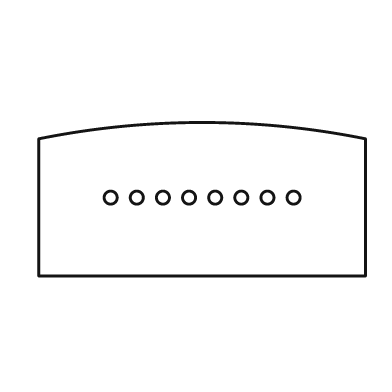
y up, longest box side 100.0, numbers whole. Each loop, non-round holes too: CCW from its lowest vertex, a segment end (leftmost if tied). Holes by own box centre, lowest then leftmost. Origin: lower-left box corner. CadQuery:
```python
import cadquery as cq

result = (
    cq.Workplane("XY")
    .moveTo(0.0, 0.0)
    .lineTo(100.0, 0.0)
    .lineTo(100.0, 42.0)
    .threePointArc((50.0, 47.0), (0.0, 42.0))
    .close()
    .moveTo(22.0, 24.0)
    .circle(2.0)
    .moveTo(30.0, 24.0)
    .circle(2.0)
    .moveTo(38.0, 24.0)
    .circle(2.0)
    .moveTo(46.0, 24.0)
    .circle(2.0)
    .moveTo(54.0, 24.0)
    .circle(2.0)
    .moveTo(62.0, 24.0)
    .circle(2.0)
    .moveTo(70.0, 24.0)
    .circle(2.0)
    .moveTo(78.0, 24.0)
    .circle(2.0)
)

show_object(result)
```